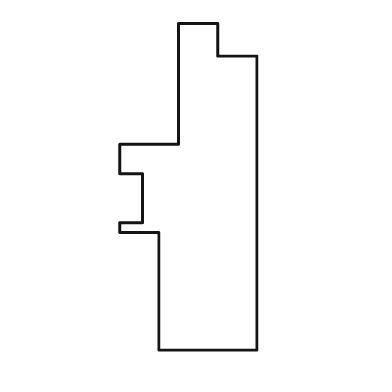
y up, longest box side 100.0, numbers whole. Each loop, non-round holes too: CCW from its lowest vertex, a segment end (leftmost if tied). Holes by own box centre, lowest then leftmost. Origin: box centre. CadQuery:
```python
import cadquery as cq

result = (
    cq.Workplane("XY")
    .moveTo(-9.0, -50.0)
    .lineTo(21.0, -50.0)
    .lineTo(21.0, 40.0)
    .lineTo(9.0, 40.0)
    .lineTo(9.0, 50.0)
    .lineTo(-3.0, 50.0)
    .lineTo(-3.0, 13.0)
    .lineTo(-21.0, 13.0)
    .lineTo(-21.0, 4.0)
    .lineTo(-14.0, 4.0)
    .lineTo(-14.0, -11.0)
    .lineTo(-21.0, -11.0)
    .lineTo(-21.0, -14.0)
    .lineTo(-9.0, -14.0)
    .close()
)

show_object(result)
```